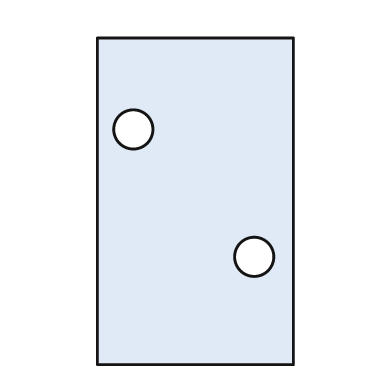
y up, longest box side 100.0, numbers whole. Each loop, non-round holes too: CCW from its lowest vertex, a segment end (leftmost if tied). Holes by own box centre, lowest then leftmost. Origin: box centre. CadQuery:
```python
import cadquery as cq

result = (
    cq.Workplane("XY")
    .moveTo(-30.0, -50.0)
    .lineTo(30.0, -50.0)
    .lineTo(30.0, 50.0)
    .lineTo(-30.0, 50.0)
    .close()
    .moveTo(18.0, -17.0)
    .circle(6.0)
    .moveTo(-19.0, 22.0)
    .circle(6.0)
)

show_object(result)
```